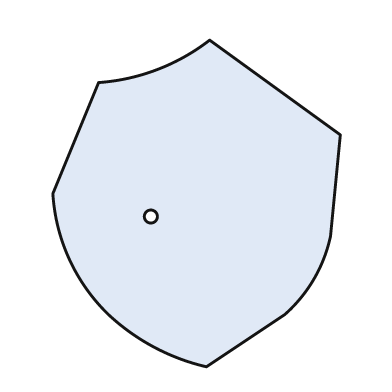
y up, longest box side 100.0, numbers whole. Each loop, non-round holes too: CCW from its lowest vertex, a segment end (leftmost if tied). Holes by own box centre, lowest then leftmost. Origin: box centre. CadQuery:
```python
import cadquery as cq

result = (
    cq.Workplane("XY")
    .moveTo(3.0, -50.0)
    .lineTo(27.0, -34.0)
    .threePointArc((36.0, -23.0), (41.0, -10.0))
    .lineTo(44.0, 21.0)
    .lineTo(4.0, 50.0)
    .threePointArc((-12.0, 41.0), (-30.0, 37.0))
    .lineTo(-44.0, 3.0)
    .threePointArc((-39.0, -17.0), (-27.0, -34.0))
    .threePointArc((-13.0, -44.0), (3.0, -50.0))
    .close()
    .moveTo(-14.0, -4.0)
    .circle(2.0)
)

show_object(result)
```